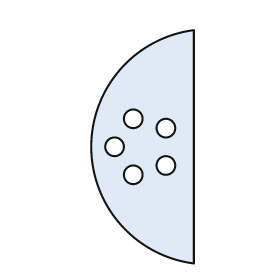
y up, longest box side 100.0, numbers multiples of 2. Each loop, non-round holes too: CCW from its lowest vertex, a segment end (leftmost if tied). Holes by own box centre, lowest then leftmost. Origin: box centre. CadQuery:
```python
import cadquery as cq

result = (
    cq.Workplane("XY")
    .moveTo(22.0, -50.0)
    .lineTo(22.0, 50.0)
    .threePointArc((-22.0, 0.0), (22.0, -50.0))
    .close()
    .moveTo(-4.0, -12.0)
    .circle(4.0)
    .moveTo(10.0, -8.0)
    .circle(4.0)
    .moveTo(-12.0, 0.0)
    .circle(4.0)
    .moveTo(10.0, 8.0)
    .circle(4.0)
    .moveTo(-4.0, 12.0)
    .circle(4.0)
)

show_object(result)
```